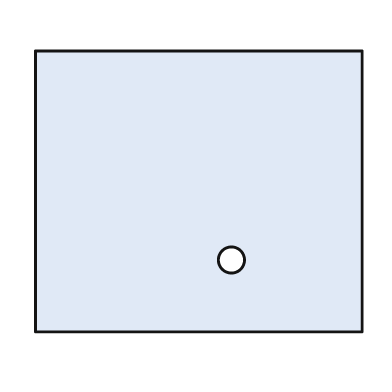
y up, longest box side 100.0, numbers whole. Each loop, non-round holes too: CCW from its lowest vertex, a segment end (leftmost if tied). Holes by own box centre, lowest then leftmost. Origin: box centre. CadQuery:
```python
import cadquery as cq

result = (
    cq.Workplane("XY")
    .moveTo(-50.0, -43.0)
    .lineTo(50.0, -43.0)
    .lineTo(50.0, 43.0)
    .lineTo(-50.0, 43.0)
    .close()
    .moveTo(10.0, -21.0)
    .circle(4.0)
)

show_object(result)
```